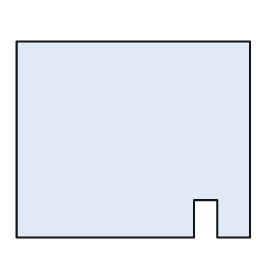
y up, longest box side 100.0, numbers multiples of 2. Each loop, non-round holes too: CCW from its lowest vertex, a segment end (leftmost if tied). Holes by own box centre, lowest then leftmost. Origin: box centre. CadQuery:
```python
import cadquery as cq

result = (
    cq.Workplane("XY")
    .moveTo(-50.0, -42.0)
    .lineTo(26.0, -42.0)
    .lineTo(26.0, -26.0)
    .lineTo(36.0, -26.0)
    .lineTo(36.0, -42.0)
    .lineTo(50.0, -42.0)
    .lineTo(50.0, 42.0)
    .lineTo(-50.0, 42.0)
    .close()
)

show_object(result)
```